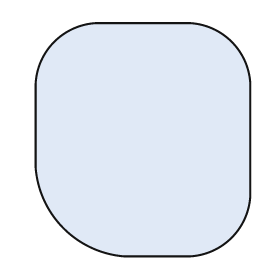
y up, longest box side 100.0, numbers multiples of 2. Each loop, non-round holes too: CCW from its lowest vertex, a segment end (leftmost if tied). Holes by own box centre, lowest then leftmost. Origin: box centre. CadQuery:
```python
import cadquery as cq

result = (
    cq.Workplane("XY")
    .moveTo(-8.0, -50.0)
    .lineTo(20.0, -50.0)
    .threePointArc((38.0, -42.0), (46.0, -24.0))
    .lineTo(46.0, 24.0)
    .threePointArc((38.0, 42.0), (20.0, 50.0))
    .lineTo(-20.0, 50.0)
    .threePointArc((-38.0, 42.0), (-46.0, 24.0))
    .lineTo(-46.0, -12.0)
    .threePointArc((-34.0, -38.0), (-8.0, -50.0))
    .close()
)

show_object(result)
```